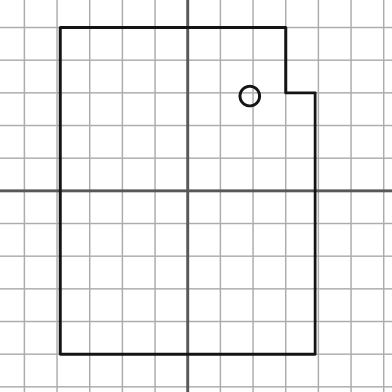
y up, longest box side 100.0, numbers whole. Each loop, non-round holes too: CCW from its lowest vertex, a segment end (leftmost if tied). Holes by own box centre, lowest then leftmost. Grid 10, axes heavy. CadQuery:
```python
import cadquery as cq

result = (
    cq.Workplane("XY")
    .moveTo(-39.0, -50.0)
    .lineTo(39.0, -50.0)
    .lineTo(39.0, 30.0)
    .lineTo(30.0, 30.0)
    .lineTo(30.0, 50.0)
    .lineTo(-39.0, 50.0)
    .close()
    .moveTo(19.0, 29.0)
    .circle(3.0)
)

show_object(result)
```